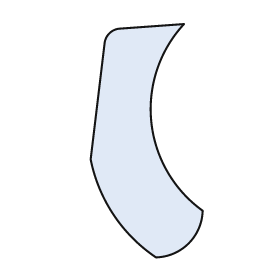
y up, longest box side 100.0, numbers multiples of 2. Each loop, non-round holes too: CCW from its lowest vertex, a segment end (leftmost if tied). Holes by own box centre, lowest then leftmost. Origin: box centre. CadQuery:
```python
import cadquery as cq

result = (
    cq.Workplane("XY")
    .moveTo(4.0, -50.0)
    .threePointArc((18.0, -44.0), (24.0, -30.0))
    .threePointArc((2.0, 8.0), (16.0, 50.0))
    .lineTo(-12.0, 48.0)
    .threePointArc((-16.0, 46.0), (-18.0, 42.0))
    .lineTo(-24.0, -8.0)
    .threePointArc((-14.0, -32.0), (4.0, -50.0))
    .close()
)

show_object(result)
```